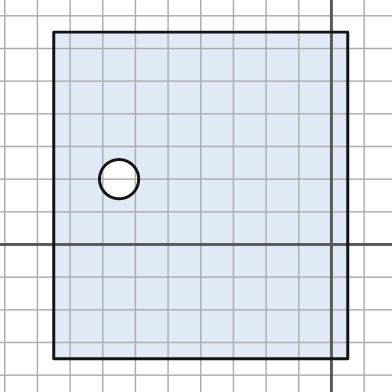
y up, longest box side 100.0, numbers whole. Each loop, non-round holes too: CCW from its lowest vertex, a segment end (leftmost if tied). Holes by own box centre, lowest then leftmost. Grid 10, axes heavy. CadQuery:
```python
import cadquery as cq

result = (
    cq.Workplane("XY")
    .moveTo(-85.0, -35.0)
    .lineTo(5.0, -35.0)
    .lineTo(5.0, 65.0)
    .lineTo(-85.0, 65.0)
    .close()
    .moveTo(-65.0, 20.0)
    .circle(6.0)
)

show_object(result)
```